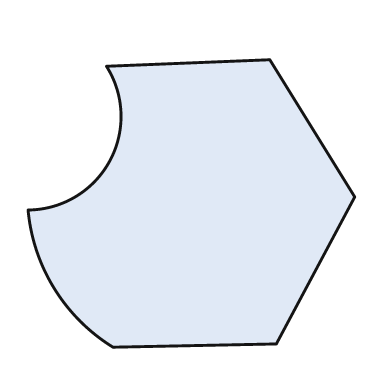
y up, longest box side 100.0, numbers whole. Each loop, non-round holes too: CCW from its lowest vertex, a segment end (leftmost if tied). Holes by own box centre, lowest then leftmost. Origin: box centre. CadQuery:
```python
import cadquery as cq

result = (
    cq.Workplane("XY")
    .moveTo(-24.0, -44.0)
    .lineTo(26.0, -43.0)
    .lineTo(50.0, 2.0)
    .lineTo(24.0, 44.0)
    .lineTo(-26.0, 42.0)
    .threePointArc((-25.0, 13.0), (-50.0, -2.0))
    .threePointArc((-42.0, -26.0), (-24.0, -44.0))
    .close()
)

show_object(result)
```